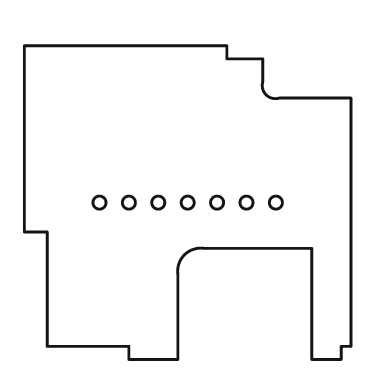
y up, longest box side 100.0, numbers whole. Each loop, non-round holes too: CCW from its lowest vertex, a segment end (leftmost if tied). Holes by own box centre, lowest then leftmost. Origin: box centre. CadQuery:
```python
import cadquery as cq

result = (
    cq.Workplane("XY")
    .moveTo(-18.0, -48.0)
    .lineTo(-3.0, -48.0)
    .lineTo(-3.0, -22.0)
    .threePointArc((-1.0, -16.0), (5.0, -14.0))
    .lineTo(38.0, -14.0)
    .lineTo(38.0, -48.0)
    .lineTo(47.0, -48.0)
    .lineTo(47.0, -44.0)
    .lineTo(50.0, -44.0)
    .lineTo(50.0, 32.0)
    .lineTo(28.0, 32.0)
    .threePointArc((24.0, 33.0), (23.0, 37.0))
    .lineTo(23.0, 44.0)
    .lineTo(12.0, 44.0)
    .lineTo(12.0, 48.0)
    .lineTo(-50.0, 48.0)
    .lineTo(-50.0, -9.0)
    .lineTo(-43.0, -9.0)
    .lineTo(-43.0, -44.0)
    .lineTo(-18.0, -44.0)
    .close()
    .moveTo(-27.0, 0.0)
    .circle(2.0)
    .moveTo(-18.0, 0.0)
    .circle(2.0)
    .moveTo(-9.0, 0.0)
    .circle(2.0)
    .moveTo(0.0, 0.0)
    .circle(2.0)
    .moveTo(9.0, 0.0)
    .circle(2.0)
    .moveTo(18.0, 0.0)
    .circle(2.0)
    .moveTo(27.0, 0.0)
    .circle(2.0)
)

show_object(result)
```